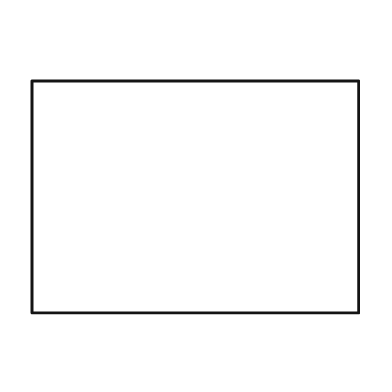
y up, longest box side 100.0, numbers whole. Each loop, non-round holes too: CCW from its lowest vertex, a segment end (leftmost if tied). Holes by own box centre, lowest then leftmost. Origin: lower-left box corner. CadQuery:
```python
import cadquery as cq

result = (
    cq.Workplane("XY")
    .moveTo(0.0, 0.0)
    .lineTo(100.0, 0.0)
    .lineTo(100.0, 71.0)
    .lineTo(0.0, 71.0)
    .close()
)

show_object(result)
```